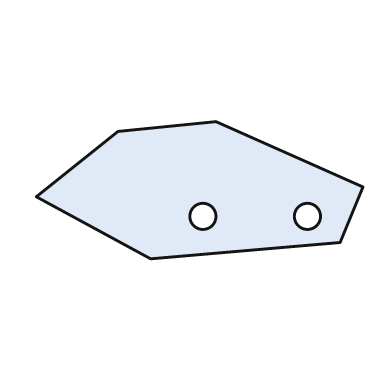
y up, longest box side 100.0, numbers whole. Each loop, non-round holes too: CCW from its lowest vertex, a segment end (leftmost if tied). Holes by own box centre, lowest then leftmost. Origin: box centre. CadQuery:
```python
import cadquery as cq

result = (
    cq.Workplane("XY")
    .moveTo(-15.0, -21.0)
    .lineTo(43.0, -16.0)
    .lineTo(50.0, 1.0)
    .lineTo(5.0, 21.0)
    .lineTo(-25.0, 18.0)
    .lineTo(-50.0, -2.0)
    .close()
    .moveTo(1.0, -8.0)
    .circle(4.0)
    .moveTo(33.0, -8.0)
    .circle(4.0)
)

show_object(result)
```